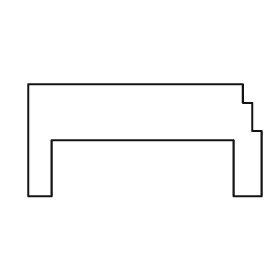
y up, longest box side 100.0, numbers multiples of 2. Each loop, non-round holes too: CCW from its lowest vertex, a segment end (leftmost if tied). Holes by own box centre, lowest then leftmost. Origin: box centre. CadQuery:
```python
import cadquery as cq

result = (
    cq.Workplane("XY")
    .moveTo(-50.0, -24.0)
    .lineTo(-40.0, -24.0)
    .lineTo(-40.0, 0.0)
    .lineTo(38.0, 0.0)
    .lineTo(38.0, -24.0)
    .lineTo(50.0, -24.0)
    .lineTo(50.0, 4.0)
    .lineTo(46.0, 4.0)
    .lineTo(46.0, 16.0)
    .lineTo(42.0, 16.0)
    .lineTo(42.0, 24.0)
    .lineTo(-50.0, 24.0)
    .close()
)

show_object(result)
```